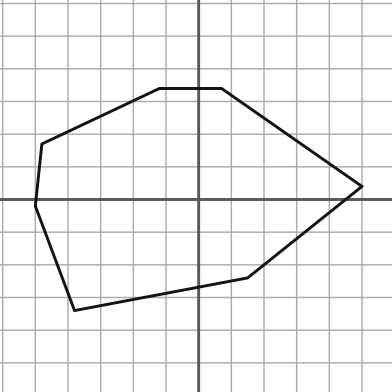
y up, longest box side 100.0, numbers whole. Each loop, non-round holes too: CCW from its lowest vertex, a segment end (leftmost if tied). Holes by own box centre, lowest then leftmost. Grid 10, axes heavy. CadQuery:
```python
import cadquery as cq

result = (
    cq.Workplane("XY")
    .moveTo(-38.0, -34.0)
    .lineTo(15.0, -24.0)
    .lineTo(50.0, 4.0)
    .lineTo(7.0, 34.0)
    .lineTo(-12.0, 34.0)
    .lineTo(-48.0, 17.0)
    .lineTo(-50.0, -2.0)
    .close()
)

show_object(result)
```